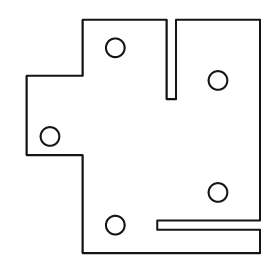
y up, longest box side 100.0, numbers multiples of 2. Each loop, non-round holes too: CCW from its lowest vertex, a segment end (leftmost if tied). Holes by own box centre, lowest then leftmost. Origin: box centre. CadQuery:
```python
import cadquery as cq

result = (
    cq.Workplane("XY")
    .moveTo(-26.0, -50.0)
    .lineTo(50.0, -50.0)
    .lineTo(50.0, -40.0)
    .lineTo(6.0, -40.0)
    .lineTo(6.0, -36.0)
    .lineTo(50.0, -36.0)
    .lineTo(50.0, 50.0)
    .lineTo(14.0, 50.0)
    .lineTo(14.0, 16.0)
    .lineTo(10.0, 16.0)
    .lineTo(10.0, 50.0)
    .lineTo(-26.0, 50.0)
    .lineTo(-26.0, 26.0)
    .lineTo(-50.0, 26.0)
    .lineTo(-50.0, -8.0)
    .lineTo(-26.0, -8.0)
    .close()
    .moveTo(-12.0, -38.0)
    .circle(4.0)
    .moveTo(32.0, -24.0)
    .circle(4.0)
    .moveTo(-40.0, 0.0)
    .circle(4.0)
    .moveTo(32.0, 24.0)
    .circle(4.0)
    .moveTo(-12.0, 38.0)
    .circle(4.0)
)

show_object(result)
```